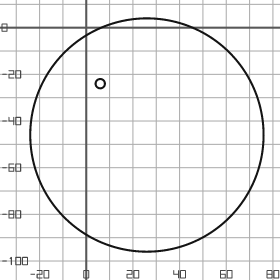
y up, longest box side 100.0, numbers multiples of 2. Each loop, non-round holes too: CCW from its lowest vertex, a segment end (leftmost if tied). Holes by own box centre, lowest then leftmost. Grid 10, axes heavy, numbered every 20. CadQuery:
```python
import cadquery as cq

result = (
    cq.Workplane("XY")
    .moveTo(26.0, -46.0)
    .circle(50.0)
    .moveTo(6.0, -24.0)
    .circle(2.0)
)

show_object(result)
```